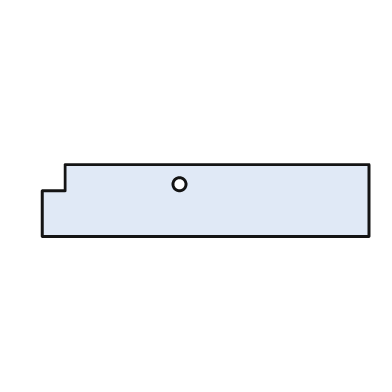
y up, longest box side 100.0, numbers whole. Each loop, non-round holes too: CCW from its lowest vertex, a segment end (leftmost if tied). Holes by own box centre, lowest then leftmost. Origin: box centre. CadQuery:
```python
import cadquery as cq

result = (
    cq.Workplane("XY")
    .moveTo(-50.0, -11.0)
    .lineTo(50.0, -11.0)
    .lineTo(50.0, 11.0)
    .lineTo(-43.0, 11.0)
    .lineTo(-43.0, 3.0)
    .lineTo(-50.0, 3.0)
    .close()
    .moveTo(-8.0, 5.0)
    .circle(2.0)
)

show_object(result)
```